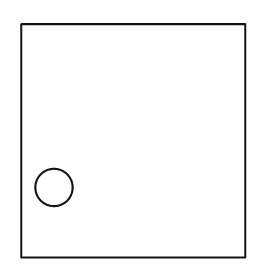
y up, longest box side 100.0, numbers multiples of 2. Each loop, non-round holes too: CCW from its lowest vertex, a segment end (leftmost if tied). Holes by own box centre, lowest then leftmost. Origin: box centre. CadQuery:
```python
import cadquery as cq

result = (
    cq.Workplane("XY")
    .moveTo(-48.0, -50.0)
    .lineTo(48.0, -50.0)
    .lineTo(48.0, 50.0)
    .lineTo(-48.0, 50.0)
    .close()
    .moveTo(-34.0, -20.0)
    .circle(8.0)
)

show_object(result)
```